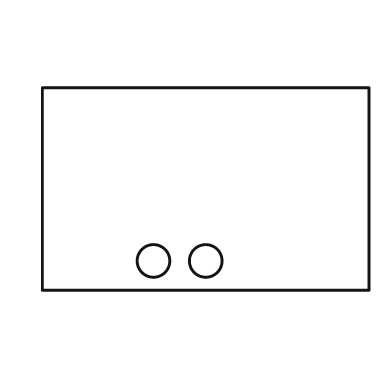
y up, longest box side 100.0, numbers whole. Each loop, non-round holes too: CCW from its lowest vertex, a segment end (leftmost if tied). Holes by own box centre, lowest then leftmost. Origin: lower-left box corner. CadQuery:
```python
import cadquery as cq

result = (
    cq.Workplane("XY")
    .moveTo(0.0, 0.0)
    .lineTo(100.0, 0.0)
    .lineTo(100.0, 62.0)
    .lineTo(0.0, 62.0)
    .close()
    .moveTo(34.0, 9.0)
    .circle(5.0)
    .moveTo(50.0, 9.0)
    .circle(5.0)
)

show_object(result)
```